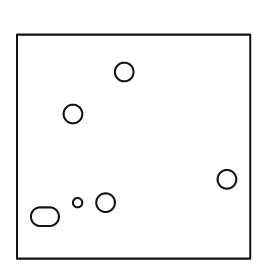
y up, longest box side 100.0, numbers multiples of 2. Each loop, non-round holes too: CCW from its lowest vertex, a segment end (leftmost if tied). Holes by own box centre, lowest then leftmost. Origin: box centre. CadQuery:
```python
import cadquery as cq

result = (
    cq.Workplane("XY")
    .moveTo(-50.0, -48.0)
    .lineTo(50.0, -48.0)
    .lineTo(50.0, 48.0)
    .lineTo(-50.0, 48.0)
    .close()
    .moveTo(-40.0, -34.0)
    .lineTo(-36.0, -34.0)
    .threePointArc((-32.0, -30.0), (-36.0, -26.0))
    .lineTo(-40.0, -26.0)
    .threePointArc((-44.0, -30.0), (-40.0, -34.0))
    .close()
    .moveTo(-24.0, -24.0)
    .circle(2.0)
    .moveTo(-12.0, -24.0)
    .circle(4.0)
    .moveTo(40.0, -14.0)
    .circle(4.0)
    .moveTo(-26.0, 14.0)
    .circle(4.0)
    .moveTo(-4.0, 32.0)
    .circle(4.0)
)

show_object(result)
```